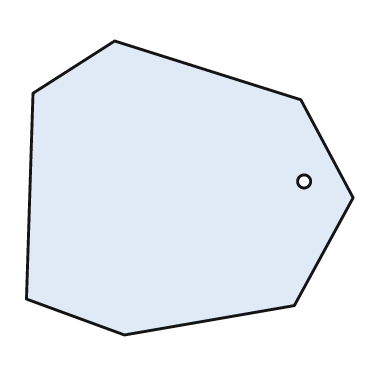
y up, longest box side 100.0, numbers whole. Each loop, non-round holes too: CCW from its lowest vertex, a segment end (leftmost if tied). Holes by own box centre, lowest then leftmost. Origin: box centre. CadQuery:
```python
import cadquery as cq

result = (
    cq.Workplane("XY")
    .moveTo(-20.0, -45.0)
    .lineTo(32.0, -36.0)
    .lineTo(50.0, -3.0)
    .lineTo(34.0, 27.0)
    .lineTo(-23.0, 45.0)
    .lineTo(-48.0, 29.0)
    .lineTo(-50.0, -34.0)
    .close()
    .moveTo(35.0, 2.0)
    .circle(2.0)
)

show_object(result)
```